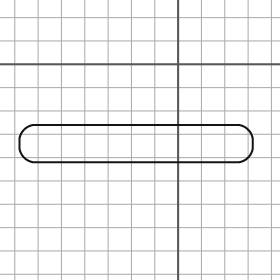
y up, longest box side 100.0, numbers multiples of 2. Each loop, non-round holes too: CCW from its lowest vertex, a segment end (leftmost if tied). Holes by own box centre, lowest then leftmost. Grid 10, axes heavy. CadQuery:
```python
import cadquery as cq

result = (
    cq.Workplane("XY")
    .moveTo(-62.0, -42.0)
    .lineTo(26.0, -42.0)
    .threePointArc((30.0, -40.0), (32.0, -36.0))
    .lineTo(32.0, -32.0)
    .threePointArc((30.0, -28.0), (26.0, -26.0))
    .lineTo(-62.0, -26.0)
    .threePointArc((-66.0, -28.0), (-68.0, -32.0))
    .lineTo(-68.0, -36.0)
    .threePointArc((-66.0, -40.0), (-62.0, -42.0))
    .close()
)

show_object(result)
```